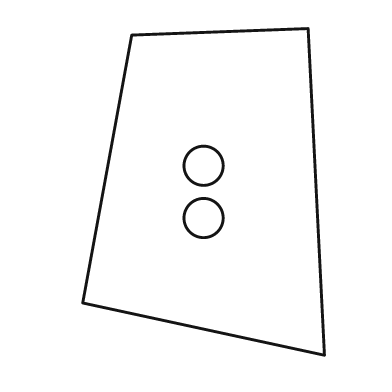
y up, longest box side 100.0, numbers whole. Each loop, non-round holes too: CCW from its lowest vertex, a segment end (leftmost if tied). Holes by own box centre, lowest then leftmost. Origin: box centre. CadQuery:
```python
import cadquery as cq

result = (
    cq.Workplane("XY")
    .moveTo(37.0, -50.0)
    .lineTo(32.0, 50.0)
    .lineTo(-22.0, 48.0)
    .lineTo(-37.0, -34.0)
    .close()
    .moveTo(0.0, -8.0)
    .circle(6.0)
    .moveTo(0.0, 8.0)
    .circle(6.0)
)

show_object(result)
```